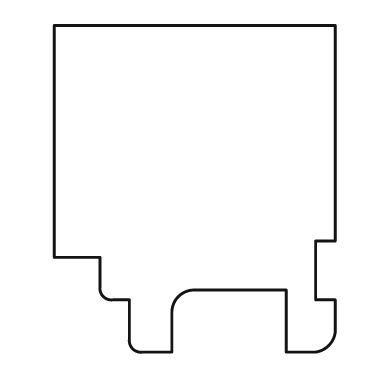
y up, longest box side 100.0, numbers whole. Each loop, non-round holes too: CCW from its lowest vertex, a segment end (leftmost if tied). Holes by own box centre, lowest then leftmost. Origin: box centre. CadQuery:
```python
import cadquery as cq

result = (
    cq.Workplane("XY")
    .moveTo(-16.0, -50.0)
    .lineTo(-7.0, -50.0)
    .lineTo(-7.0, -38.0)
    .threePointArc((-5.0, -33.0), (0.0, -31.0))
    .lineTo(28.0, -31.0)
    .lineTo(28.0, -50.0)
    .lineTo(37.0, -50.0)
    .threePointArc((41.0, -48.0), (43.0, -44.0))
    .lineTo(43.0, -34.0)
    .lineTo(37.0, -34.0)
    .lineTo(37.0, -16.0)
    .lineTo(43.0, -16.0)
    .lineTo(43.0, 50.0)
    .lineTo(-43.0, 50.0)
    .lineTo(-43.0, -21.0)
    .lineTo(-29.0, -21.0)
    .lineTo(-29.0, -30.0)
    .threePointArc((-28.0, -33.0), (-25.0, -34.0))
    .lineTo(-20.0, -34.0)
    .lineTo(-20.0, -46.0)
    .threePointArc((-19.0, -49.0), (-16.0, -50.0))
    .close()
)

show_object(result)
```